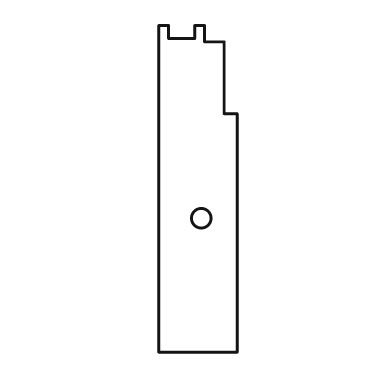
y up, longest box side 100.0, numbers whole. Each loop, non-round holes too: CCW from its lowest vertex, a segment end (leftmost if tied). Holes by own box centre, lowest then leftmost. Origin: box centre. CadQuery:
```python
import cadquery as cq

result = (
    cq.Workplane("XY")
    .moveTo(-12.0, -50.0)
    .lineTo(12.0, -50.0)
    .lineTo(12.0, 23.0)
    .lineTo(8.0, 23.0)
    .lineTo(8.0, 45.0)
    .lineTo(2.0, 45.0)
    .lineTo(2.0, 50.0)
    .lineTo(-1.0, 50.0)
    .lineTo(-1.0, 46.0)
    .lineTo(-9.0, 46.0)
    .lineTo(-9.0, 50.0)
    .lineTo(-12.0, 50.0)
    .close()
    .moveTo(1.0, -9.0)
    .circle(3.0)
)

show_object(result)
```